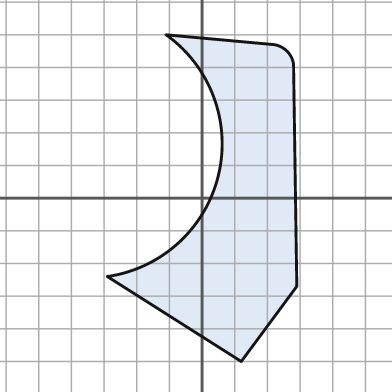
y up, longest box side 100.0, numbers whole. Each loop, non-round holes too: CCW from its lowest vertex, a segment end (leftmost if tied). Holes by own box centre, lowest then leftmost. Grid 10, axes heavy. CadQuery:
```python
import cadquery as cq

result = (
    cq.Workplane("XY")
    .moveTo(12.0, -50.0)
    .lineTo(29.0, -27.0)
    .lineTo(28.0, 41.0)
    .threePointArc((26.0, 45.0), (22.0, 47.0))
    .lineTo(-11.0, 50.0)
    .threePointArc((5.0, 7.0), (-29.0, -24.0))
    .close()
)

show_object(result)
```